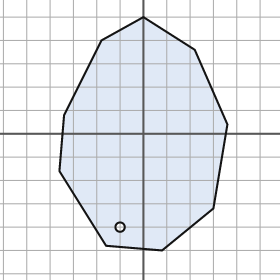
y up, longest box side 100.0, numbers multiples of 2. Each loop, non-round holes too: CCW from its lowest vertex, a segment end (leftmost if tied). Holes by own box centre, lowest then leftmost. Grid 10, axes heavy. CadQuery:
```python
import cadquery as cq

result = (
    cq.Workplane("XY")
    .moveTo(8.0, -50.0)
    .lineTo(30.0, -32.0)
    .lineTo(36.0, 4.0)
    .lineTo(22.0, 36.0)
    .lineTo(0.0, 50.0)
    .lineTo(-18.0, 40.0)
    .lineTo(-34.0, 8.0)
    .lineTo(-36.0, -16.0)
    .lineTo(-16.0, -48.0)
    .close()
    .moveTo(-10.0, -40.0)
    .circle(2.0)
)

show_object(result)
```